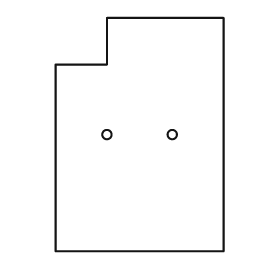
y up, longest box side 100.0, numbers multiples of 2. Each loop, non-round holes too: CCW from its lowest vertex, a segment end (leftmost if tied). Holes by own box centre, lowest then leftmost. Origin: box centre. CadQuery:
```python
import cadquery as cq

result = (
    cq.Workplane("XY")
    .moveTo(-36.0, -50.0)
    .lineTo(36.0, -50.0)
    .lineTo(36.0, 50.0)
    .lineTo(-14.0, 50.0)
    .lineTo(-14.0, 30.0)
    .lineTo(-36.0, 30.0)
    .close()
    .moveTo(-14.0, 0.0)
    .circle(2.0)
    .moveTo(14.0, 0.0)
    .circle(2.0)
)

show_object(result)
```